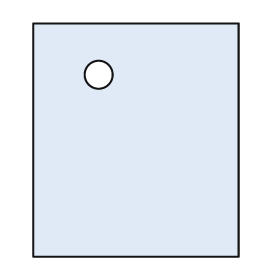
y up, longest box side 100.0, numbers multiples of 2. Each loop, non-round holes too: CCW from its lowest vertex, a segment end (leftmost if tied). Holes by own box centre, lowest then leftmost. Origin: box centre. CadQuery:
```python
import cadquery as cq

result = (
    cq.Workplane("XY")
    .moveTo(-44.0, -50.0)
    .lineTo(44.0, -50.0)
    .lineTo(44.0, 50.0)
    .lineTo(-44.0, 50.0)
    .close()
    .moveTo(-16.0, 28.0)
    .circle(6.0)
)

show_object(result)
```